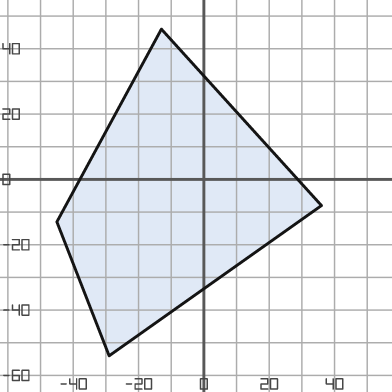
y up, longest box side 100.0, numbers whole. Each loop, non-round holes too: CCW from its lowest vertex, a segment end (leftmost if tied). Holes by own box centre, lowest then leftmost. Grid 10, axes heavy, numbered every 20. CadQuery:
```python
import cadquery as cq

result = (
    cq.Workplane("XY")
    .moveTo(-29.0, -54.0)
    .lineTo(36.0, -8.0)
    .lineTo(-13.0, 46.0)
    .lineTo(-45.0, -13.0)
    .close()
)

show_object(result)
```